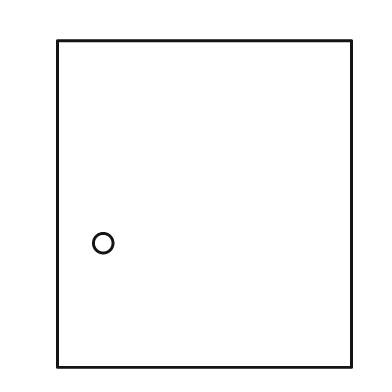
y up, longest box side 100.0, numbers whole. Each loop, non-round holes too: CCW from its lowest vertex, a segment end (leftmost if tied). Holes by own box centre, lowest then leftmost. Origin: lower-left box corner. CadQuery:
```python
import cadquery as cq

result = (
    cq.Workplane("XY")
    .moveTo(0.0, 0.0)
    .lineTo(90.0, 0.0)
    .lineTo(90.0, 100.0)
    .lineTo(0.0, 100.0)
    .close()
    .moveTo(14.0, 38.0)
    .circle(3.0)
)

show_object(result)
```